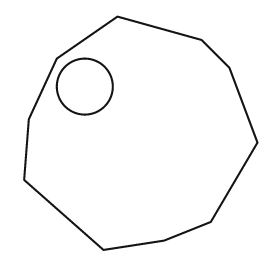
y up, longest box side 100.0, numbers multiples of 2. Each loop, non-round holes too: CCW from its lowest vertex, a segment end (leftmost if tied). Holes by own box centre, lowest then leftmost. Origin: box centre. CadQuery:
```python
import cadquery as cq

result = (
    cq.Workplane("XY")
    .moveTo(-16.0, -50.0)
    .lineTo(10.0, -46.0)
    .lineTo(30.0, -38.0)
    .lineTo(50.0, -4.0)
    .lineTo(38.0, 28.0)
    .lineTo(26.0, 40.0)
    .lineTo(-10.0, 50.0)
    .lineTo(-36.0, 32.0)
    .lineTo(-48.0, 6.0)
    .lineTo(-50.0, -20.0)
    .close()
    .moveTo(-24.0, 20.0)
    .circle(12.0)
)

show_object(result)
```